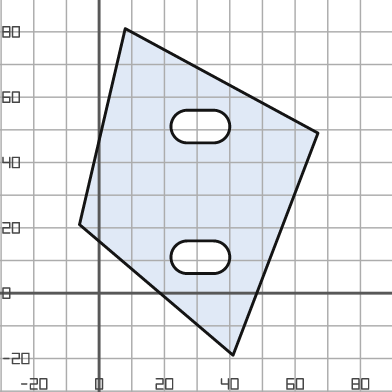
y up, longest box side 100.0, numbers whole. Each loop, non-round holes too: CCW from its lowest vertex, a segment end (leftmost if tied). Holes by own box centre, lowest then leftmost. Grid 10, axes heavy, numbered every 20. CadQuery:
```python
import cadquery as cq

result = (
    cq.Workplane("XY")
    .moveTo(41.0, -19.0)
    .lineTo(67.0, 49.0)
    .lineTo(8.0, 81.0)
    .lineTo(-6.0, 21.0)
    .close()
    .moveTo(27.0, 6.0)
    .lineTo(35.0, 6.0)
    .threePointArc((40.0, 11.0), (35.0, 16.0))
    .lineTo(27.0, 16.0)
    .threePointArc((22.0, 11.0), (27.0, 6.0))
    .close()
    .moveTo(27.0, 46.0)
    .lineTo(35.0, 46.0)
    .threePointArc((40.0, 51.0), (35.0, 56.0))
    .lineTo(27.0, 56.0)
    .threePointArc((22.0, 51.0), (27.0, 46.0))
    .close()
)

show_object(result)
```